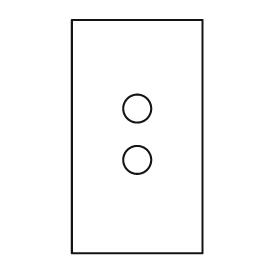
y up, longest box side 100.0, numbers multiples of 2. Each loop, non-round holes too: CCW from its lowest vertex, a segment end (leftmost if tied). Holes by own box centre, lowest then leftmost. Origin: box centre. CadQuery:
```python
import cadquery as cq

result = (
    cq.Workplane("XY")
    .moveTo(-28.0, -50.0)
    .lineTo(28.0, -50.0)
    .lineTo(28.0, 50.0)
    .lineTo(-28.0, 50.0)
    .close()
    .moveTo(0.0, -10.0)
    .circle(6.0)
    .moveTo(0.0, 12.0)
    .circle(6.0)
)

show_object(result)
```